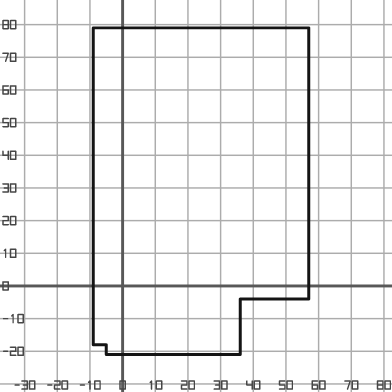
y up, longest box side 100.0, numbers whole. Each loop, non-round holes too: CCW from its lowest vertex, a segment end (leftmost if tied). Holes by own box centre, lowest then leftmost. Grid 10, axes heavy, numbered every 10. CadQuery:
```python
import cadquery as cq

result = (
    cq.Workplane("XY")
    .moveTo(-5.0, -21.0)
    .lineTo(36.0, -21.0)
    .lineTo(36.0, -4.0)
    .lineTo(57.0, -4.0)
    .lineTo(57.0, 79.0)
    .lineTo(-9.0, 79.0)
    .lineTo(-9.0, -18.0)
    .lineTo(-5.0, -18.0)
    .close()
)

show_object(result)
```